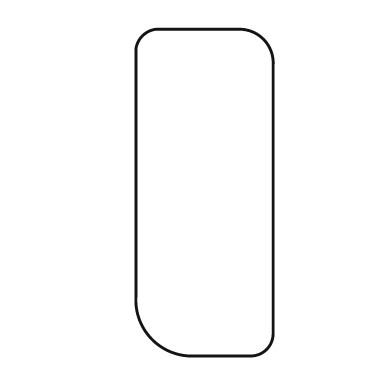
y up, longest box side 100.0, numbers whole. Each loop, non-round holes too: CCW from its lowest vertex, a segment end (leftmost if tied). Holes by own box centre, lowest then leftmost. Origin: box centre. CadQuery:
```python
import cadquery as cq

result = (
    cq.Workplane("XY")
    .moveTo(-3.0, -50.0)
    .lineTo(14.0, -50.0)
    .threePointArc((19.0, -48.0), (21.0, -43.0))
    .lineTo(21.0, 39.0)
    .threePointArc((18.0, 47.0), (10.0, 50.0))
    .lineTo(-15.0, 50.0)
    .threePointArc((-19.0, 48.0), (-21.0, 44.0))
    .lineTo(-21.0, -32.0)
    .threePointArc((-16.0, -45.0), (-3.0, -50.0))
    .close()
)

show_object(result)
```